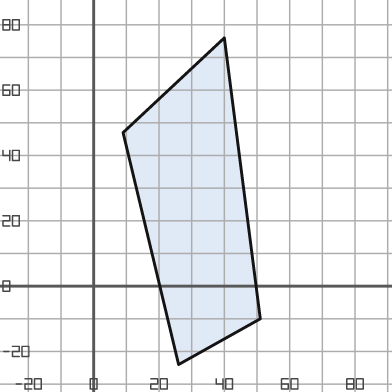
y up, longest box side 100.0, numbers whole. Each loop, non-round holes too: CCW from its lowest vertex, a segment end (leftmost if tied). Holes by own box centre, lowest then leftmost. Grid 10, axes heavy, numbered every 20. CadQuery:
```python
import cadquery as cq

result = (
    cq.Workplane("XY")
    .moveTo(26.0, -24.0)
    .lineTo(51.0, -10.0)
    .lineTo(40.0, 76.0)
    .lineTo(9.0, 47.0)
    .close()
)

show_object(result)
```